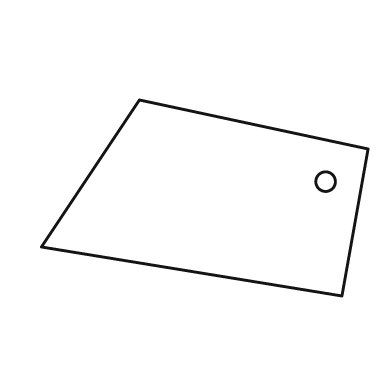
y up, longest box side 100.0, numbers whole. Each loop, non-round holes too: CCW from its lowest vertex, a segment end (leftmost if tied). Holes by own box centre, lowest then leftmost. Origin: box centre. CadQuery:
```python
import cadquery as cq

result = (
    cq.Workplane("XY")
    .moveTo(42.0, -30.0)
    .lineTo(50.0, 15.0)
    .lineTo(-20.0, 30.0)
    .lineTo(-50.0, -15.0)
    .close()
    .moveTo(37.0, 5.0)
    .circle(3.0)
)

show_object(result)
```